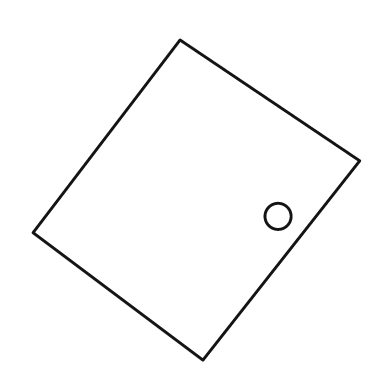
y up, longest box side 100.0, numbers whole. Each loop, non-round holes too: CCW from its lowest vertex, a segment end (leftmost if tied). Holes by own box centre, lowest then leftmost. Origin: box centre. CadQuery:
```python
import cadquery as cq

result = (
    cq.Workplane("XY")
    .moveTo(2.0, -49.0)
    .lineTo(50.0, 12.0)
    .lineTo(-5.0, 49.0)
    .lineTo(-50.0, -10.0)
    .close()
    .moveTo(25.0, -5.0)
    .circle(4.0)
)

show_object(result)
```